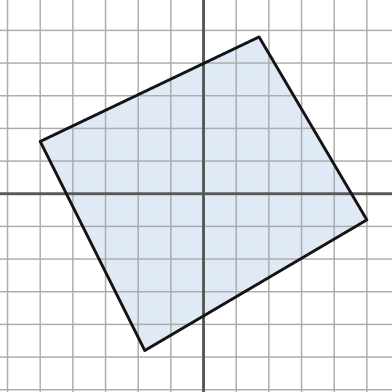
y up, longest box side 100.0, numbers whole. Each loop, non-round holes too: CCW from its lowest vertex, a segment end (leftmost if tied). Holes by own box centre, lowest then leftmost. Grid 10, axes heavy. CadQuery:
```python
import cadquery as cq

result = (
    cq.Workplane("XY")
    .moveTo(-18.0, -48.0)
    .lineTo(50.0, -8.0)
    .lineTo(17.0, 48.0)
    .lineTo(-50.0, 16.0)
    .close()
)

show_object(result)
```